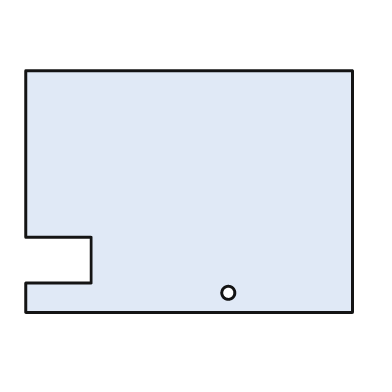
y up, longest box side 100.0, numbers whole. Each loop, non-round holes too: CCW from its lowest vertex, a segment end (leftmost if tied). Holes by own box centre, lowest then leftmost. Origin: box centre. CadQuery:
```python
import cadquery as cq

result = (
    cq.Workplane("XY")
    .moveTo(-50.0, -37.0)
    .lineTo(50.0, -37.0)
    .lineTo(50.0, 37.0)
    .lineTo(-50.0, 37.0)
    .lineTo(-50.0, -14.0)
    .lineTo(-30.0, -14.0)
    .lineTo(-30.0, -28.0)
    .lineTo(-50.0, -28.0)
    .close()
    .moveTo(12.0, -31.0)
    .circle(2.0)
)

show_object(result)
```